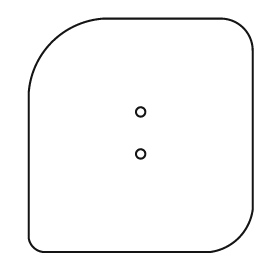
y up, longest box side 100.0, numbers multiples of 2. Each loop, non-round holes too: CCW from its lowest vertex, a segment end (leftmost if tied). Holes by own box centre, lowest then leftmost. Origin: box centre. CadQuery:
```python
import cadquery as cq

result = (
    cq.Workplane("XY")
    .moveTo(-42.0, -50.0)
    .lineTo(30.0, -50.0)
    .threePointArc((42.0, -44.0), (48.0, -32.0))
    .lineTo(48.0, 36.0)
    .threePointArc((44.0, 46.0), (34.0, 50.0))
    .lineTo(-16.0, 50.0)
    .threePointArc((-38.0, 40.0), (-48.0, 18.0))
    .lineTo(-48.0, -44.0)
    .threePointArc((-46.0, -48.0), (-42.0, -50.0))
    .close()
    .moveTo(0.0, -8.0)
    .circle(2.0)
    .moveTo(0.0, 10.0)
    .circle(2.0)
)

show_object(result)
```